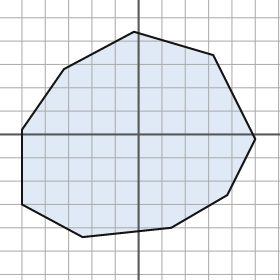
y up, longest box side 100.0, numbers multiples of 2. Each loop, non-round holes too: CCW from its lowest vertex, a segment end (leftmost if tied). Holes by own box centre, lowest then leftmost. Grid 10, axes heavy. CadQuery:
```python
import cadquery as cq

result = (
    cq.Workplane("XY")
    .moveTo(-24.0, -44.0)
    .lineTo(14.0, -40.0)
    .lineTo(38.0, -26.0)
    .lineTo(50.0, -2.0)
    .lineTo(32.0, 34.0)
    .lineTo(-2.0, 44.0)
    .lineTo(-32.0, 28.0)
    .lineTo(-50.0, 2.0)
    .lineTo(-50.0, -30.0)
    .close()
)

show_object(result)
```